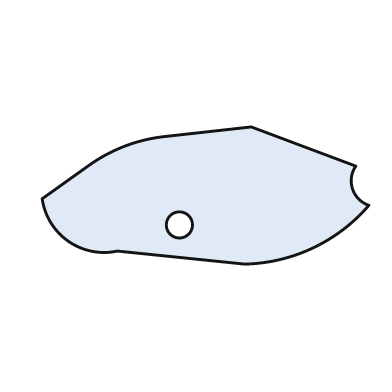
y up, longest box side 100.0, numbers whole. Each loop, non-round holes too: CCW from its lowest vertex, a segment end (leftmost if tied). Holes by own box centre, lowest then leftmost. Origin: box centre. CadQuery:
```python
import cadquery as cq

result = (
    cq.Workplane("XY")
    .moveTo(12.0, -21.0)
    .threePointArc((33.0, -16.0), (50.0, -3.0))
    .threePointArc((45.0, 2.0), (46.0, 9.0))
    .lineTo(14.0, 21.0)
    .lineTo(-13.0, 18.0)
    .threePointArc((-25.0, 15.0), (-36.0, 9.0))
    .lineTo(-50.0, -1.0)
    .threePointArc((-42.0, -14.0), (-27.0, -17.0))
    .close()
    .moveTo(-8.0, -9.0)
    .circle(4.0)
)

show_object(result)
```